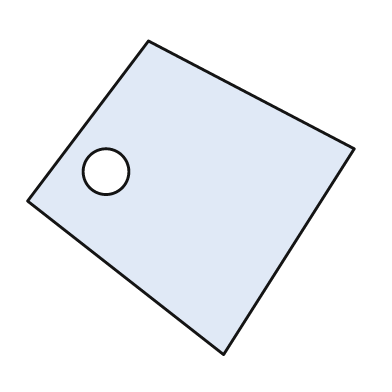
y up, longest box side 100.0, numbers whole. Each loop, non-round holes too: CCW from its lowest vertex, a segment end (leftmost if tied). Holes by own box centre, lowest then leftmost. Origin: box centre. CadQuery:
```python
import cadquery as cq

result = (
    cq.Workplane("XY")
    .moveTo(10.0, -48.0)
    .lineTo(50.0, 15.0)
    .lineTo(-13.0, 48.0)
    .lineTo(-50.0, -1.0)
    .close()
    .moveTo(-26.0, 8.0)
    .circle(7.0)
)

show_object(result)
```